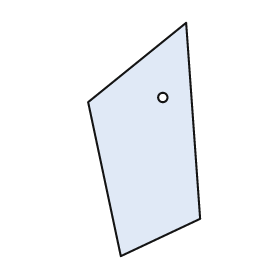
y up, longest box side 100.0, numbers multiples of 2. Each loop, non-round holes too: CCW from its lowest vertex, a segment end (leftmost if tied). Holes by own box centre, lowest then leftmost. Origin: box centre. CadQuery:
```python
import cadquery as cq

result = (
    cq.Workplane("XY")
    .moveTo(-10.0, -50.0)
    .lineTo(24.0, -34.0)
    .lineTo(18.0, 50.0)
    .lineTo(-24.0, 16.0)
    .close()
    .moveTo(8.0, 18.0)
    .circle(2.0)
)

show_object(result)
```